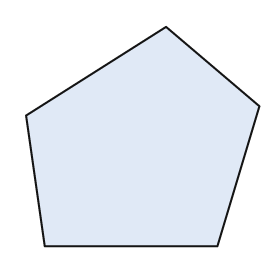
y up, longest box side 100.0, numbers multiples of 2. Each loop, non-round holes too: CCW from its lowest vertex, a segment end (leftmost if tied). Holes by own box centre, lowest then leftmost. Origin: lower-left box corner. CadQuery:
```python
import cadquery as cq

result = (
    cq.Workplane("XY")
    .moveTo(8.0, 0.0)
    .lineTo(82.0, 0.0)
    .lineTo(100.0, 60.0)
    .lineTo(60.0, 94.0)
    .lineTo(0.0, 56.0)
    .close()
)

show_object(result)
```